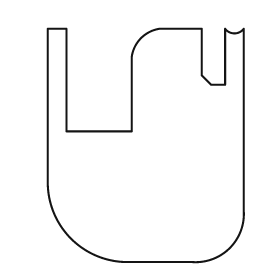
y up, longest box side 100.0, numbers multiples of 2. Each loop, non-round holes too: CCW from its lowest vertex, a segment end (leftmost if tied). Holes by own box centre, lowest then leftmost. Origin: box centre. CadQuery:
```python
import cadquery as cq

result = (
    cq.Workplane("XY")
    .moveTo(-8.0, -50.0)
    .lineTo(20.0, -50.0)
    .threePointArc((36.0, -44.0), (42.0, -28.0))
    .lineTo(42.0, 50.0)
    .threePointArc((38.0, 48.0), (34.0, 50.0))
    .lineTo(34.0, 26.0)
    .lineTo(28.0, 26.0)
    .lineTo(24.0, 30.0)
    .lineTo(24.0, 50.0)
    .lineTo(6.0, 50.0)
    .threePointArc((-2.0, 46.0), (-6.0, 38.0))
    .lineTo(-6.0, 6.0)
    .lineTo(-34.0, 6.0)
    .lineTo(-34.0, 50.0)
    .lineTo(-42.0, 50.0)
    .lineTo(-42.0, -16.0)
    .threePointArc((-32.0, -40.0), (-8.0, -50.0))
    .close()
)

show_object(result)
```